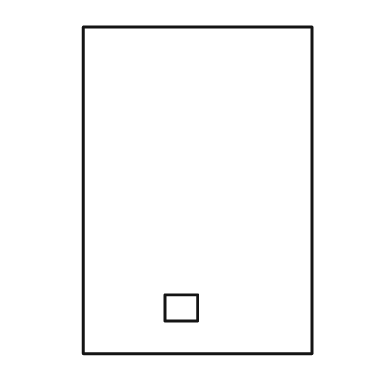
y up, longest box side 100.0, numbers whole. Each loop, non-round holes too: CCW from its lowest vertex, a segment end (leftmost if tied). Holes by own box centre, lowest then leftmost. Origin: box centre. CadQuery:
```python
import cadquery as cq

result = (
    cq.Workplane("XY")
    .moveTo(-35.0, -50.0)
    .lineTo(35.0, -50.0)
    .lineTo(35.0, 50.0)
    .lineTo(-35.0, 50.0)
    .close()
    .moveTo(-10.0, -40.0)
    .lineTo(0.0, -40.0)
    .lineTo(0.0, -32.0)
    .lineTo(-10.0, -32.0)
    .close()
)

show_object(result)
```